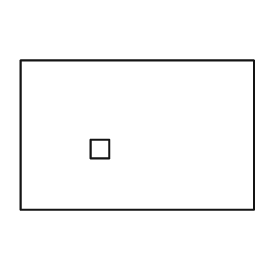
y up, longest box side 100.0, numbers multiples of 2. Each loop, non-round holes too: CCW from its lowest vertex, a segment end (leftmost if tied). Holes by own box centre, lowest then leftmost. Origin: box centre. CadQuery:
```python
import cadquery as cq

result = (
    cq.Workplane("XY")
    .moveTo(-50.0, -32.0)
    .lineTo(50.0, -32.0)
    .lineTo(50.0, 32.0)
    .lineTo(-50.0, 32.0)
    .close()
    .moveTo(-20.0, -10.0)
    .lineTo(-12.0, -10.0)
    .lineTo(-12.0, -2.0)
    .lineTo(-20.0, -2.0)
    .close()
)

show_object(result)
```